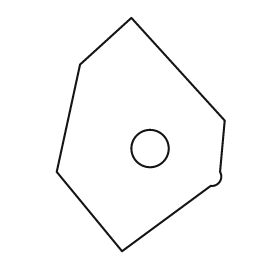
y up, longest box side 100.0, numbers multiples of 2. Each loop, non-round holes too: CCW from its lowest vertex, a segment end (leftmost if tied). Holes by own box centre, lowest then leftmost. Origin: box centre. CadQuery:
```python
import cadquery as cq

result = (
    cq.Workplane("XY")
    .moveTo(-8.0, -50.0)
    .lineTo(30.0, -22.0)
    .threePointArc((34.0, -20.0), (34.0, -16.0))
    .lineTo(36.0, 6.0)
    .lineTo(-4.0, 50.0)
    .lineTo(-26.0, 30.0)
    .lineTo(-36.0, -16.0)
    .close()
    .moveTo(4.0, -6.0)
    .circle(8.0)
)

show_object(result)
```